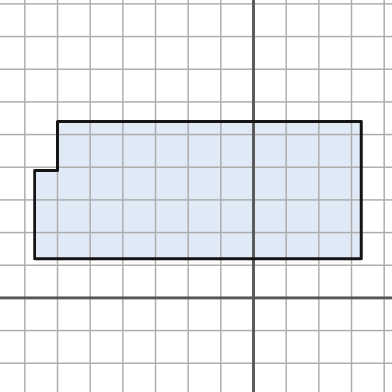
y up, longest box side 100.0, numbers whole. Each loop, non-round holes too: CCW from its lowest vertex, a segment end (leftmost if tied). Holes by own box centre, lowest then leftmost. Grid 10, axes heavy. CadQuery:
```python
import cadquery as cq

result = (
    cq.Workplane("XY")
    .moveTo(-67.0, 12.0)
    .lineTo(33.0, 12.0)
    .lineTo(33.0, 54.0)
    .lineTo(-60.0, 54.0)
    .lineTo(-60.0, 39.0)
    .lineTo(-67.0, 39.0)
    .close()
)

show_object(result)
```